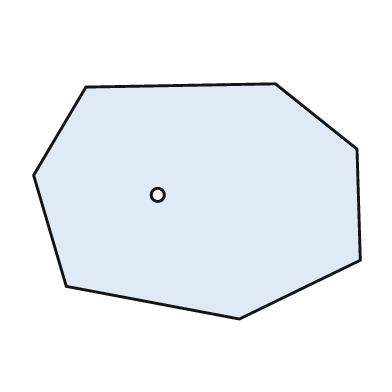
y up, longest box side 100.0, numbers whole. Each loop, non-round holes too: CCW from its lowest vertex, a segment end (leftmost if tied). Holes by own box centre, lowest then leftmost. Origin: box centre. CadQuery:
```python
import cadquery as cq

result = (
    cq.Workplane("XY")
    .moveTo(13.0, -36.0)
    .lineTo(50.0, -18.0)
    .lineTo(49.0, 16.0)
    .lineTo(24.0, 36.0)
    .lineTo(-34.0, 35.0)
    .lineTo(-50.0, 8.0)
    .lineTo(-40.0, -26.0)
    .close()
    .moveTo(-12.0, 2.0)
    .circle(2.0)
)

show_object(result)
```